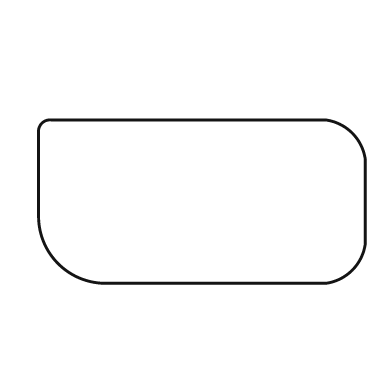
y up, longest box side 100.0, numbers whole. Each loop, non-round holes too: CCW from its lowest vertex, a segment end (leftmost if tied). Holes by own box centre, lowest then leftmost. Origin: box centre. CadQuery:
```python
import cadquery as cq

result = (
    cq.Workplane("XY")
    .moveTo(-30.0, -25.0)
    .lineTo(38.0, -25.0)
    .threePointArc((46.0, -21.0), (50.0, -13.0))
    .lineTo(50.0, 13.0)
    .threePointArc((46.0, 21.0), (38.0, 25.0))
    .lineTo(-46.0, 25.0)
    .threePointArc((-49.0, 24.0), (-50.0, 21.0))
    .lineTo(-50.0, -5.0)
    .threePointArc((-44.0, -19.0), (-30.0, -25.0))
    .close()
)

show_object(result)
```